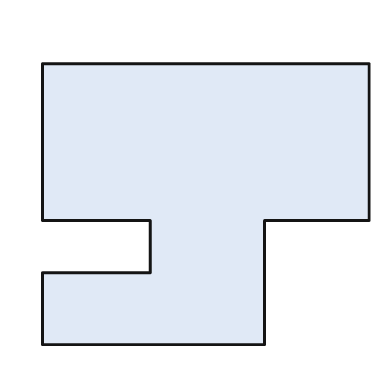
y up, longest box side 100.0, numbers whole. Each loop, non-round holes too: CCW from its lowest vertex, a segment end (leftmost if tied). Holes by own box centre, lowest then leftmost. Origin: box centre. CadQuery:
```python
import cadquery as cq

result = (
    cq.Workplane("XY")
    .moveTo(-50.0, -43.0)
    .lineTo(18.0, -43.0)
    .lineTo(18.0, -5.0)
    .lineTo(50.0, -5.0)
    .lineTo(50.0, 43.0)
    .lineTo(-50.0, 43.0)
    .lineTo(-50.0, -5.0)
    .lineTo(-17.0, -5.0)
    .lineTo(-17.0, -21.0)
    .lineTo(-50.0, -21.0)
    .close()
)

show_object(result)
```